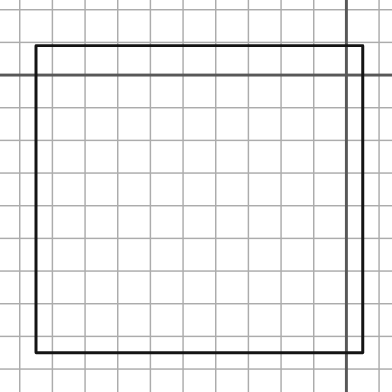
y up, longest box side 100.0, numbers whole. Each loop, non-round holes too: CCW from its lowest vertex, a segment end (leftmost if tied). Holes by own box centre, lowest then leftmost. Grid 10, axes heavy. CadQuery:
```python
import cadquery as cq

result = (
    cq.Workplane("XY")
    .moveTo(-95.0, -85.0)
    .lineTo(5.0, -85.0)
    .lineTo(5.0, 9.0)
    .lineTo(-95.0, 9.0)
    .close()
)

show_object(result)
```